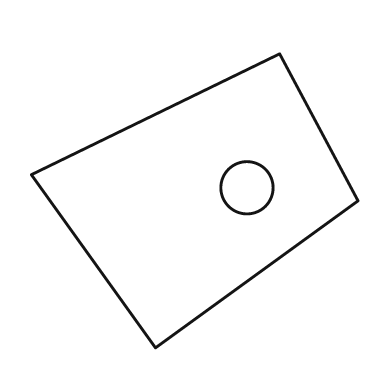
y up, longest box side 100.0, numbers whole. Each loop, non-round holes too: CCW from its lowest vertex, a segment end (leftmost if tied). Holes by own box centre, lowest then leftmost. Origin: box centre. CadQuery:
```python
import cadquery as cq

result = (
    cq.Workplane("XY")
    .moveTo(-12.0, -45.0)
    .lineTo(50.0, 0.0)
    .lineTo(26.0, 45.0)
    .lineTo(-50.0, 8.0)
    .close()
    .moveTo(16.0, 4.0)
    .circle(8.0)
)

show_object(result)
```